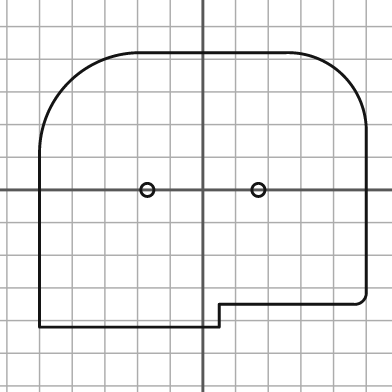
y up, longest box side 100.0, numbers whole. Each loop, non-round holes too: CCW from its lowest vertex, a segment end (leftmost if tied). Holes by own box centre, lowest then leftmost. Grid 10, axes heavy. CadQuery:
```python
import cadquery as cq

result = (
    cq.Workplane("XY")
    .moveTo(-50.0, -42.0)
    .lineTo(5.0, -42.0)
    .lineTo(5.0, -35.0)
    .lineTo(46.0, -35.0)
    .threePointArc((49.0, -34.0), (50.0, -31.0))
    .lineTo(50.0, 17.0)
    .threePointArc((43.0, 35.0), (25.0, 42.0))
    .lineTo(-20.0, 42.0)
    .threePointArc((-41.0, 33.0), (-50.0, 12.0))
    .close()
    .moveTo(-17.0, 0.0)
    .circle(2.0)
    .moveTo(17.0, 0.0)
    .circle(2.0)
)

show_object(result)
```